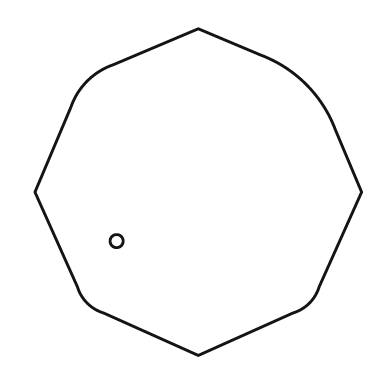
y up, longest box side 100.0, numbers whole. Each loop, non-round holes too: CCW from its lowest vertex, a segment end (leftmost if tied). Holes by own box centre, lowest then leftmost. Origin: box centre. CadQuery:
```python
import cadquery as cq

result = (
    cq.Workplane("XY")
    .moveTo(0.0, -50.0)
    .lineTo(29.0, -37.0)
    .threePointArc((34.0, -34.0), (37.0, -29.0))
    .lineTo(50.0, 0.0)
    .lineTo(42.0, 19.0)
    .threePointArc((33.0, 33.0), (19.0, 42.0))
    .lineTo(0.0, 50.0)
    .lineTo(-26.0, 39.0)
    .threePointArc((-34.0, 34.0), (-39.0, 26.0))
    .lineTo(-50.0, 0.0)
    .lineTo(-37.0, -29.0)
    .threePointArc((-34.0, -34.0), (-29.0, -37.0))
    .close()
    .moveTo(-25.0, -15.0)
    .circle(2.0)
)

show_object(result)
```